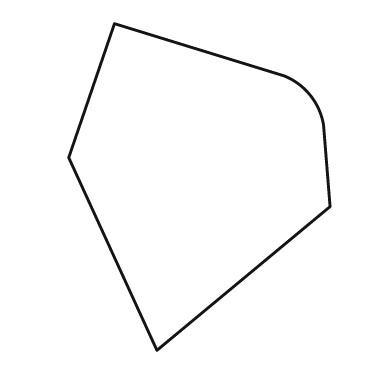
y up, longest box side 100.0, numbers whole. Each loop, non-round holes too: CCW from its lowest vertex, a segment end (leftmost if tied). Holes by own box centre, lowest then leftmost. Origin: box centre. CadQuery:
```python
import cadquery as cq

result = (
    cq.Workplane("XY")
    .moveTo(-13.0, -50.0)
    .lineTo(40.0, -6.0)
    .lineTo(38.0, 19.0)
    .threePointArc((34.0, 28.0), (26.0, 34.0))
    .lineTo(-26.0, 50.0)
    .lineTo(-40.0, 9.0)
    .close()
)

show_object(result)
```